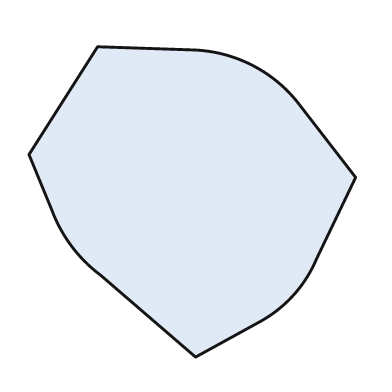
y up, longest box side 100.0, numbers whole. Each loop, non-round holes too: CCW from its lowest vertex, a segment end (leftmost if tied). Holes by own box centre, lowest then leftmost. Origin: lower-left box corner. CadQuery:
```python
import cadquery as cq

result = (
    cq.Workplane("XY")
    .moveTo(51.0, 0.0)
    .lineTo(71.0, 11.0)
    .threePointArc((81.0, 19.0), (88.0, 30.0))
    .lineTo(100.0, 55.0)
    .lineTo(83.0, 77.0)
    .threePointArc((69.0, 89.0), (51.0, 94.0))
    .lineTo(21.0, 95.0)
    .lineTo(0.0, 62.0)
    .lineTo(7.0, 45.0)
    .threePointArc((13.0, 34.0), (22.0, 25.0))
    .close()
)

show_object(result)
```